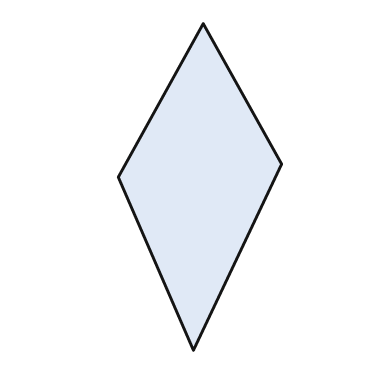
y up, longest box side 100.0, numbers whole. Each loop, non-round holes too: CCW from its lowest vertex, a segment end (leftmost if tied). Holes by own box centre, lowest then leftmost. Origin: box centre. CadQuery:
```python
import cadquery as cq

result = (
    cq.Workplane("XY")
    .moveTo(-2.0, -50.0)
    .lineTo(25.0, 7.0)
    .lineTo(1.0, 50.0)
    .lineTo(-25.0, 3.0)
    .close()
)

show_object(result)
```